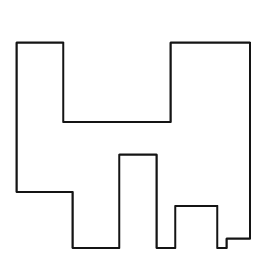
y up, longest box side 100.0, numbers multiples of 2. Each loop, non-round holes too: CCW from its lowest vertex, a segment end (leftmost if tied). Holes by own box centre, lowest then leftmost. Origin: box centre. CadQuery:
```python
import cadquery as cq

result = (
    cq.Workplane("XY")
    .moveTo(-26.0, -44.0)
    .lineTo(-6.0, -44.0)
    .lineTo(-6.0, -4.0)
    .lineTo(10.0, -4.0)
    .lineTo(10.0, -44.0)
    .lineTo(18.0, -44.0)
    .lineTo(18.0, -26.0)
    .lineTo(36.0, -26.0)
    .lineTo(36.0, -44.0)
    .lineTo(40.0, -44.0)
    .lineTo(40.0, -40.0)
    .lineTo(50.0, -40.0)
    .lineTo(50.0, 44.0)
    .lineTo(16.0, 44.0)
    .lineTo(16.0, 10.0)
    .lineTo(-30.0, 10.0)
    .lineTo(-30.0, 44.0)
    .lineTo(-50.0, 44.0)
    .lineTo(-50.0, -20.0)
    .lineTo(-26.0, -20.0)
    .close()
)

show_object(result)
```